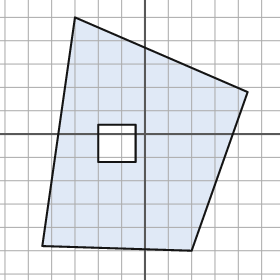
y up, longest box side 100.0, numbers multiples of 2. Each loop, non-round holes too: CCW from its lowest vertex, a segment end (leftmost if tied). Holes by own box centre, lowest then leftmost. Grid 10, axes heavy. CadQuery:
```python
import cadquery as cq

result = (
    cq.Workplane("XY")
    .moveTo(20.0, -50.0)
    .lineTo(44.0, 18.0)
    .lineTo(-30.0, 50.0)
    .lineTo(-44.0, -48.0)
    .close()
    .moveTo(-20.0, -12.0)
    .lineTo(-4.0, -12.0)
    .lineTo(-4.0, 4.0)
    .lineTo(-20.0, 4.0)
    .close()
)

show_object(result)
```